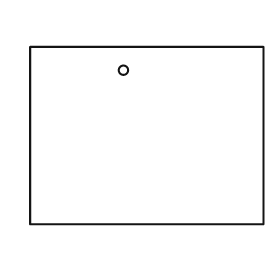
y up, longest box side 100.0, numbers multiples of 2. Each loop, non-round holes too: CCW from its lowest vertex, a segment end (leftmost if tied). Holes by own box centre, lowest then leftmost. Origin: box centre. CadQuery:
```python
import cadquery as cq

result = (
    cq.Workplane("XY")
    .moveTo(-50.0, -38.0)
    .lineTo(50.0, -38.0)
    .lineTo(50.0, 38.0)
    .lineTo(-50.0, 38.0)
    .close()
    .moveTo(-10.0, 28.0)
    .circle(2.0)
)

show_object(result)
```